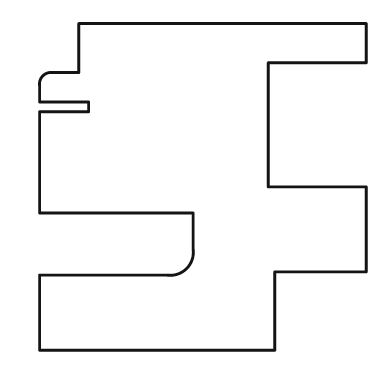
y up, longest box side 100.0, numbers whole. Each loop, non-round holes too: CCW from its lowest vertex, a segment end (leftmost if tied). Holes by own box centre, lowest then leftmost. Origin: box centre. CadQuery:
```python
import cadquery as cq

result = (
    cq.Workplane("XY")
    .moveTo(-50.0, -50.0)
    .lineTo(22.0, -50.0)
    .lineTo(22.0, -26.0)
    .lineTo(50.0, -26.0)
    .lineTo(50.0, 0.0)
    .lineTo(20.0, 0.0)
    .lineTo(20.0, 38.0)
    .lineTo(50.0, 38.0)
    .lineTo(50.0, 50.0)
    .lineTo(-38.0, 50.0)
    .lineTo(-38.0, 35.0)
    .lineTo(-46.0, 35.0)
    .threePointArc((-49.0, 34.0), (-50.0, 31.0))
    .lineTo(-50.0, 26.0)
    .lineTo(-35.0, 26.0)
    .lineTo(-35.0, 23.0)
    .lineTo(-50.0, 23.0)
    .lineTo(-50.0, -8.0)
    .lineTo(-3.0, -8.0)
    .lineTo(-3.0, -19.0)
    .threePointArc((-5.0, -25.0), (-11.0, -27.0))
    .lineTo(-50.0, -27.0)
    .close()
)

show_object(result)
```